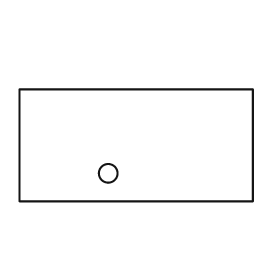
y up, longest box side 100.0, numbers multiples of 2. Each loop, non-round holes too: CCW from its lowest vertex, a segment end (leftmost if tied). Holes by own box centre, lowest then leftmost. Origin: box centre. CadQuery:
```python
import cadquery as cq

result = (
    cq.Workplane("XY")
    .moveTo(-50.0, -24.0)
    .lineTo(50.0, -24.0)
    .lineTo(50.0, 24.0)
    .lineTo(-50.0, 24.0)
    .close()
    .moveTo(-12.0, -12.0)
    .circle(4.0)
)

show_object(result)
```